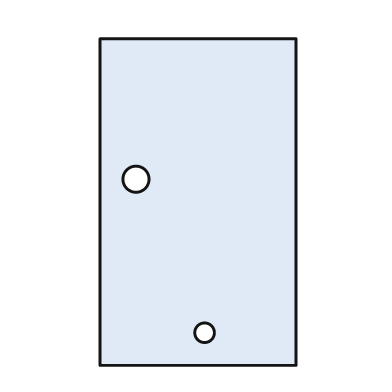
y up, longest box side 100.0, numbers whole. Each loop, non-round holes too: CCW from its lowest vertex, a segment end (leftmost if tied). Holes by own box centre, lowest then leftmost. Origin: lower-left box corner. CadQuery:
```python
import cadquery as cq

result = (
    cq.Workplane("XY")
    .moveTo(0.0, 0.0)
    .lineTo(60.0, 0.0)
    .lineTo(60.0, 100.0)
    .lineTo(0.0, 100.0)
    .close()
    .moveTo(32.0, 10.0)
    .circle(3.0)
    .moveTo(11.0, 57.0)
    .circle(4.0)
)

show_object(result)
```